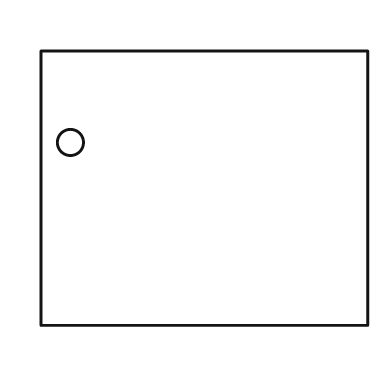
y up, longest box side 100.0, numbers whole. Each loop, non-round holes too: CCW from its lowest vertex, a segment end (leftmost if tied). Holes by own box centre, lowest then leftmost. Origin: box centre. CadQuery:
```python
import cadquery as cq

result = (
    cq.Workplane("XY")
    .moveTo(-50.0, -42.0)
    .lineTo(50.0, -42.0)
    .lineTo(50.0, 42.0)
    .lineTo(-50.0, 42.0)
    .close()
    .moveTo(-41.0, 14.0)
    .circle(4.0)
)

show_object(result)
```